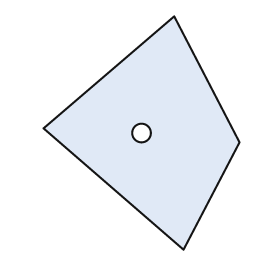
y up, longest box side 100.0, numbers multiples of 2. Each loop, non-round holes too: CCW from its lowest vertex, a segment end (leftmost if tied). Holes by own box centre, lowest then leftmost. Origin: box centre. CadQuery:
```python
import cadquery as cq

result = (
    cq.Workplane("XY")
    .moveTo(18.0, -50.0)
    .lineTo(42.0, -4.0)
    .lineTo(14.0, 50.0)
    .lineTo(-42.0, 2.0)
    .close()
    .moveTo(0.0, 0.0)
    .circle(4.0)
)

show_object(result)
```